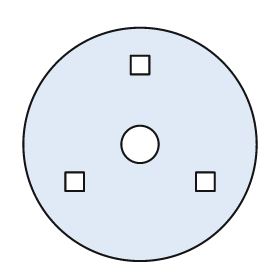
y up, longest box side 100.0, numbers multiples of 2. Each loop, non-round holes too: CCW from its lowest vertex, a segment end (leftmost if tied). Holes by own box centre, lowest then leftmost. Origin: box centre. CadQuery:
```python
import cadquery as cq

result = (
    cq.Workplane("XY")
    .moveTo(0.0, 0.0)
    .circle(50.0)
    .moveTo(-32.0, -20.0)
    .lineTo(-24.0, -20.0)
    .lineTo(-24.0, -12.0)
    .lineTo(-32.0, -12.0)
    .close()
    .moveTo(24.0, -20.0)
    .lineTo(32.0, -20.0)
    .lineTo(32.0, -12.0)
    .lineTo(24.0, -12.0)
    .close()
    .moveTo(0.0, 0.0)
    .circle(8.0)
    .moveTo(-4.0, 30.0)
    .lineTo(4.0, 30.0)
    .lineTo(4.0, 38.0)
    .lineTo(-4.0, 38.0)
    .close()
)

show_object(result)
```